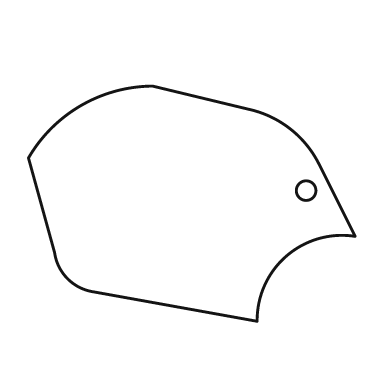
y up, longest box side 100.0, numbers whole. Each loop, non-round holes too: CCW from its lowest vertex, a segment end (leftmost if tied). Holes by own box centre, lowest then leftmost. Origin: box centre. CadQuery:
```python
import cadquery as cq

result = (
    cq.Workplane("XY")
    .moveTo(20.0, -36.0)
    .threePointArc((29.0, -16.0), (50.0, -10.0))
    .lineTo(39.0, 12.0)
    .threePointArc((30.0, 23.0), (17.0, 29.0))
    .lineTo(-12.0, 36.0)
    .threePointArc((-34.0, 30.0), (-50.0, 14.0))
    .lineTo(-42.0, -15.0)
    .threePointArc((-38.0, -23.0), (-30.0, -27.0))
    .close()
    .moveTo(35.0, 4.0)
    .circle(3.0)
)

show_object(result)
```